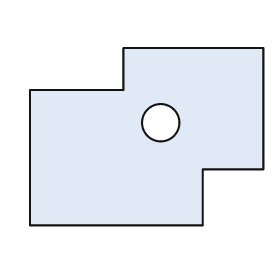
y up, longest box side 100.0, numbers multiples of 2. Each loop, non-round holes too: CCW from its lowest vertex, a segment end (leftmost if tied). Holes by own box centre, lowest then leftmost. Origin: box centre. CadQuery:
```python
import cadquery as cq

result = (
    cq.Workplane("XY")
    .moveTo(-50.0, -38.0)
    .lineTo(24.0, -38.0)
    .lineTo(24.0, -14.0)
    .lineTo(50.0, -14.0)
    .lineTo(50.0, 38.0)
    .lineTo(-10.0, 38.0)
    .lineTo(-10.0, 20.0)
    .lineTo(-50.0, 20.0)
    .close()
    .moveTo(6.0, 6.0)
    .circle(8.0)
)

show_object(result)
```